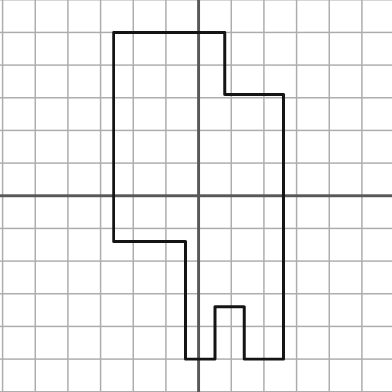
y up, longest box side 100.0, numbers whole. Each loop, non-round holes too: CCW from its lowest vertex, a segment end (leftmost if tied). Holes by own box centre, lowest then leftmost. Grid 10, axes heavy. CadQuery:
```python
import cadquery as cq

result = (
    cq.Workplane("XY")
    .moveTo(-4.0, -50.0)
    .lineTo(5.0, -50.0)
    .lineTo(5.0, -34.0)
    .lineTo(14.0, -34.0)
    .lineTo(14.0, -50.0)
    .lineTo(26.0, -50.0)
    .lineTo(26.0, 31.0)
    .lineTo(8.0, 31.0)
    .lineTo(8.0, 50.0)
    .lineTo(-26.0, 50.0)
    .lineTo(-26.0, -14.0)
    .lineTo(-4.0, -14.0)
    .close()
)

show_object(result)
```